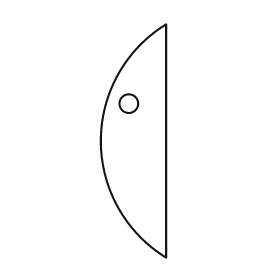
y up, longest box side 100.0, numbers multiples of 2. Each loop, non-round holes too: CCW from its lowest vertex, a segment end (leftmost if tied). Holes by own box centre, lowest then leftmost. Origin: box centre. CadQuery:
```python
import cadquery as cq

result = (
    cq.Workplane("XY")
    .moveTo(14.0, -50.0)
    .lineTo(14.0, 50.0)
    .threePointArc((-14.0, 0.0), (14.0, -50.0))
    .close()
    .moveTo(-2.0, 16.0)
    .circle(4.0)
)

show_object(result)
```